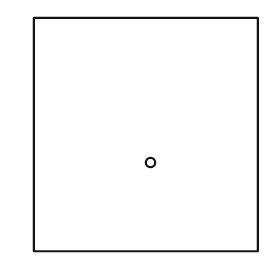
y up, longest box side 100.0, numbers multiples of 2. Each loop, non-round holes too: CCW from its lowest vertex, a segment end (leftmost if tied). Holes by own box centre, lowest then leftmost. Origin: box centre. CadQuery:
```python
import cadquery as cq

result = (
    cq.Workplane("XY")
    .moveTo(-48.0, -50.0)
    .lineTo(48.0, -50.0)
    .lineTo(48.0, 50.0)
    .lineTo(-48.0, 50.0)
    .close()
    .moveTo(2.0, -12.0)
    .circle(2.0)
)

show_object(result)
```